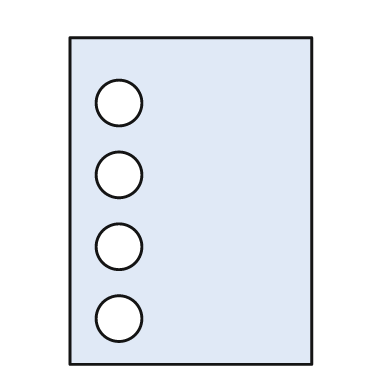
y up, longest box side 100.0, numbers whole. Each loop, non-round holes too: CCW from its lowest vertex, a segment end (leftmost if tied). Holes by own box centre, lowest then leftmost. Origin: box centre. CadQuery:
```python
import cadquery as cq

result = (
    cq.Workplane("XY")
    .moveTo(-37.0, -50.0)
    .lineTo(37.0, -50.0)
    .lineTo(37.0, 50.0)
    .lineTo(-37.0, 50.0)
    .close()
    .moveTo(-22.0, -36.0)
    .circle(7.0)
    .moveTo(-22.0, -14.0)
    .circle(7.0)
    .moveTo(-22.0, 8.0)
    .circle(7.0)
    .moveTo(-22.0, 30.0)
    .circle(7.0)
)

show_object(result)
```